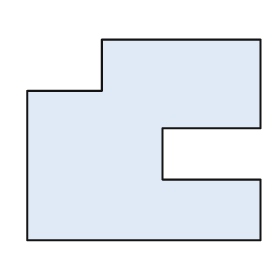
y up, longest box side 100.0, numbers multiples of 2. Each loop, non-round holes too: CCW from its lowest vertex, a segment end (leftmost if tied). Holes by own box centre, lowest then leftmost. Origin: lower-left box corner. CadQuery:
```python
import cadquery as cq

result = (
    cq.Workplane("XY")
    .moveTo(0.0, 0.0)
    .lineTo(100.0, 0.0)
    .lineTo(100.0, 26.0)
    .lineTo(58.0, 26.0)
    .lineTo(58.0, 48.0)
    .lineTo(100.0, 48.0)
    .lineTo(100.0, 86.0)
    .lineTo(32.0, 86.0)
    .lineTo(32.0, 64.0)
    .lineTo(0.0, 64.0)
    .close()
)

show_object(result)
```